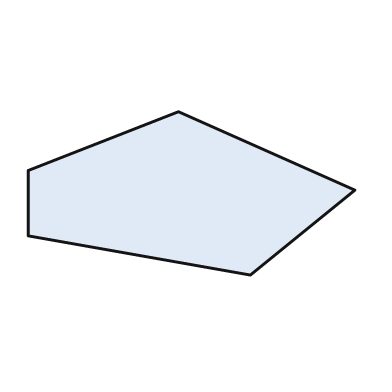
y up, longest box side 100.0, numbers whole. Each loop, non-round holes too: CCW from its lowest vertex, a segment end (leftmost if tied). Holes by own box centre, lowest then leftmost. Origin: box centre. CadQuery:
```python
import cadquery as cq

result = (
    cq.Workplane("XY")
    .moveTo(18.0, -25.0)
    .lineTo(50.0, 1.0)
    .lineTo(-4.0, 25.0)
    .lineTo(-50.0, 7.0)
    .lineTo(-50.0, -13.0)
    .close()
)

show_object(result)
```